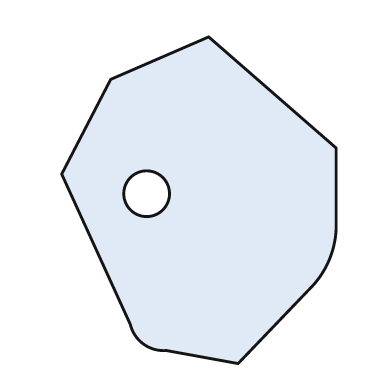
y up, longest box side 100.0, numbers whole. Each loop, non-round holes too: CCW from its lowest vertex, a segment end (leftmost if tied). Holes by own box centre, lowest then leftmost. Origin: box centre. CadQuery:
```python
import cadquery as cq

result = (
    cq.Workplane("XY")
    .moveTo(12.0, -50.0)
    .lineTo(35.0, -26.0)
    .threePointArc((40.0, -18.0), (42.0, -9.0))
    .lineTo(42.0, 16.0)
    .lineTo(3.0, 50.0)
    .lineTo(-27.0, 37.0)
    .lineTo(-42.0, 8.0)
    .lineTo(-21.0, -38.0)
    .threePointArc((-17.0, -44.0), (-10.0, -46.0))
    .close()
    .moveTo(-16.0, 2.0)
    .circle(7.0)
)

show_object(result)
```